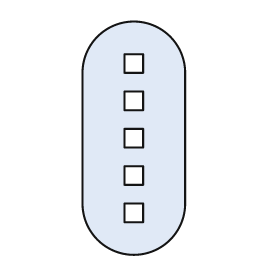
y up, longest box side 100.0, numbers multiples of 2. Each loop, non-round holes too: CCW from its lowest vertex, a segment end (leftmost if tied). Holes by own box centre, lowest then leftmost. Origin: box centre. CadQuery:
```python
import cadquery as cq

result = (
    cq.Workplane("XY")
    .moveTo(-22.0, -28.0)
    .threePointArc((0.0, -50.0), (22.0, -28.0))
    .lineTo(22.0, 28.0)
    .threePointArc((0.0, 50.0), (-22.0, 28.0))
    .close()
    .moveTo(-4.0, -36.0)
    .lineTo(4.0, -36.0)
    .lineTo(4.0, -28.0)
    .lineTo(-4.0, -28.0)
    .close()
    .moveTo(-4.0, -20.0)
    .lineTo(4.0, -20.0)
    .lineTo(4.0, -12.0)
    .lineTo(-4.0, -12.0)
    .close()
    .moveTo(-4.0, -4.0)
    .lineTo(4.0, -4.0)
    .lineTo(4.0, 4.0)
    .lineTo(-4.0, 4.0)
    .close()
    .moveTo(-4.0, 12.0)
    .lineTo(4.0, 12.0)
    .lineTo(4.0, 20.0)
    .lineTo(-4.0, 20.0)
    .close()
    .moveTo(-4.0, 28.0)
    .lineTo(4.0, 28.0)
    .lineTo(4.0, 36.0)
    .lineTo(-4.0, 36.0)
    .close()
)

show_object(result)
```